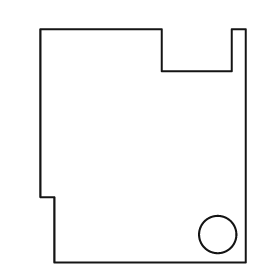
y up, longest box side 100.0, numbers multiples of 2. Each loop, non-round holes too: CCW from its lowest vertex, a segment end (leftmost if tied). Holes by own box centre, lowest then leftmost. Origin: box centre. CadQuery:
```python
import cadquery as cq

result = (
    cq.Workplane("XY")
    .moveTo(-38.0, -50.0)
    .lineTo(44.0, -50.0)
    .lineTo(44.0, 50.0)
    .lineTo(38.0, 50.0)
    .lineTo(38.0, 32.0)
    .lineTo(8.0, 32.0)
    .lineTo(8.0, 50.0)
    .lineTo(-44.0, 50.0)
    .lineTo(-44.0, -22.0)
    .lineTo(-38.0, -22.0)
    .close()
    .moveTo(32.0, -38.0)
    .circle(8.0)
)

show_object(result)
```